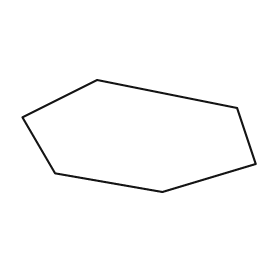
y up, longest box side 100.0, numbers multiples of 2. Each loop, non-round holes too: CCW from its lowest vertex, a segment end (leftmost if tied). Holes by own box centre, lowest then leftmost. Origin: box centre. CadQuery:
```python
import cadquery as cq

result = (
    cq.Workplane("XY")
    .moveTo(10.0, -24.0)
    .lineTo(50.0, -12.0)
    .lineTo(42.0, 12.0)
    .lineTo(-18.0, 24.0)
    .lineTo(-50.0, 8.0)
    .lineTo(-36.0, -16.0)
    .close()
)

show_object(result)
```